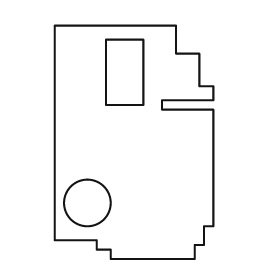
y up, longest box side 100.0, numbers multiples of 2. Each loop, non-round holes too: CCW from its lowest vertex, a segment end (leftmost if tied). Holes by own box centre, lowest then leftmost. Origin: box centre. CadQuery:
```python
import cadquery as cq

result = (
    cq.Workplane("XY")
    .moveTo(-10.0, -50.0)
    .lineTo(26.0, -50.0)
    .lineTo(26.0, -44.0)
    .lineTo(30.0, -44.0)
    .lineTo(30.0, -36.0)
    .lineTo(34.0, -36.0)
    .lineTo(34.0, 14.0)
    .lineTo(12.0, 14.0)
    .lineTo(12.0, 18.0)
    .lineTo(34.0, 18.0)
    .lineTo(34.0, 24.0)
    .lineTo(28.0, 24.0)
    .lineTo(28.0, 38.0)
    .lineTo(18.0, 38.0)
    .lineTo(18.0, 50.0)
    .lineTo(-34.0, 50.0)
    .lineTo(-34.0, -42.0)
    .lineTo(-16.0, -42.0)
    .lineTo(-16.0, -46.0)
    .lineTo(-10.0, -46.0)
    .close()
    .moveTo(-20.0, -26.0)
    .circle(10.0)
    .moveTo(-12.0, 16.0)
    .lineTo(4.0, 16.0)
    .lineTo(4.0, 44.0)
    .lineTo(-12.0, 44.0)
    .close()
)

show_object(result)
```